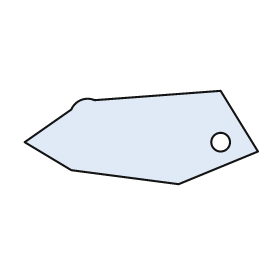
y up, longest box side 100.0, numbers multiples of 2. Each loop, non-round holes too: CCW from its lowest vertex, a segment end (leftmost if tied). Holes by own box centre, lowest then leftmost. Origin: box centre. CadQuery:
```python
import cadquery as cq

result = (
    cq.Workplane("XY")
    .moveTo(16.0, -20.0)
    .lineTo(50.0, -6.0)
    .lineTo(34.0, 20.0)
    .lineTo(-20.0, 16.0)
    .threePointArc((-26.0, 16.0), (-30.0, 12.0))
    .lineTo(-50.0, -2.0)
    .lineTo(-30.0, -14.0)
    .close()
    .moveTo(34.0, -2.0)
    .circle(4.0)
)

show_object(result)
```